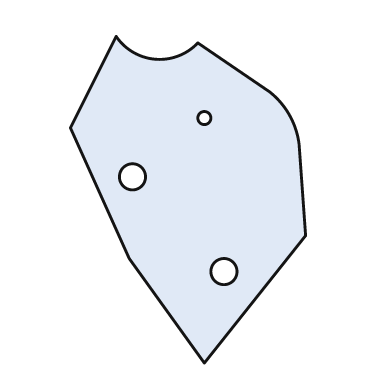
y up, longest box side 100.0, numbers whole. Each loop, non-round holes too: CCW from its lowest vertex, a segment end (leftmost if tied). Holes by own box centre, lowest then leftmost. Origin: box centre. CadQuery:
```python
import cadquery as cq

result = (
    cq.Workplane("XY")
    .moveTo(5.0, -50.0)
    .lineTo(36.0, -11.0)
    .lineTo(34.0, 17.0)
    .threePointArc((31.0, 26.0), (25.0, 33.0))
    .lineTo(3.0, 48.0)
    .threePointArc((-10.0, 43.0), (-22.0, 50.0))
    .lineTo(-36.0, 22.0)
    .lineTo(-18.0, -18.0)
    .close()
    .moveTo(11.0, -22.0)
    .circle(4.0)
    .moveTo(-17.0, 7.0)
    .circle(4.0)
    .moveTo(5.0, 25.0)
    .circle(2.0)
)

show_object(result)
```